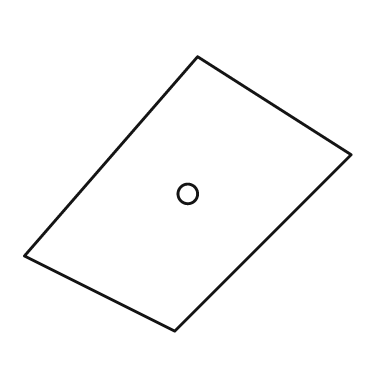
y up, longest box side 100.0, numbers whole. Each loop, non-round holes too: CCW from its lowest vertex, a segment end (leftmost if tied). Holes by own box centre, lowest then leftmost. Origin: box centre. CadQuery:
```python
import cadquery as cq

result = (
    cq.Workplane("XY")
    .moveTo(-4.0, -42.0)
    .lineTo(50.0, 12.0)
    .lineTo(3.0, 42.0)
    .lineTo(-50.0, -19.0)
    .close()
    .moveTo(0.0, 0.0)
    .circle(3.0)
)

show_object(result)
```